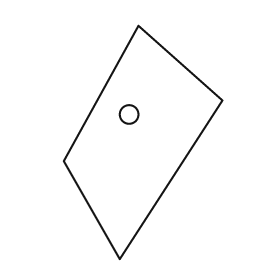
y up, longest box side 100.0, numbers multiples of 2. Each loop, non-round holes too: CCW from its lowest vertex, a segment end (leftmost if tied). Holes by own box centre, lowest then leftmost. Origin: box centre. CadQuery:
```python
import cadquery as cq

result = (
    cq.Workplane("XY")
    .moveTo(-10.0, -50.0)
    .lineTo(34.0, 18.0)
    .lineTo(-2.0, 50.0)
    .lineTo(-34.0, -8.0)
    .close()
    .moveTo(-6.0, 12.0)
    .circle(4.0)
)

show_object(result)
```